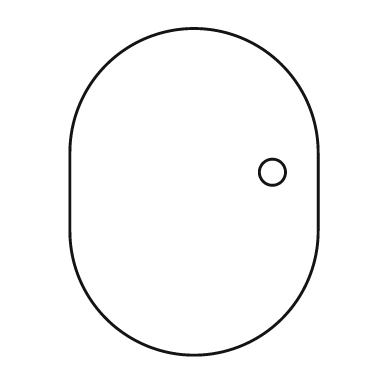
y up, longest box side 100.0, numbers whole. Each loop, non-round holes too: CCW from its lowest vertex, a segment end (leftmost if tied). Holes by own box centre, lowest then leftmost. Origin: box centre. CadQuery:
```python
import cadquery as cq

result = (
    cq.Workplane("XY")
    .moveTo(-38.0, -12.0)
    .threePointArc((0.0, -50.0), (38.0, -12.0))
    .lineTo(38.0, 12.0)
    .threePointArc((0.0, 50.0), (-38.0, 12.0))
    .close()
    .moveTo(24.0, 6.0)
    .circle(4.0)
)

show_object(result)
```